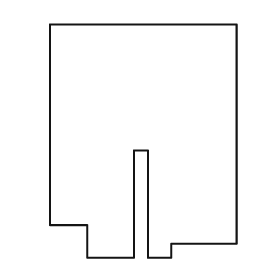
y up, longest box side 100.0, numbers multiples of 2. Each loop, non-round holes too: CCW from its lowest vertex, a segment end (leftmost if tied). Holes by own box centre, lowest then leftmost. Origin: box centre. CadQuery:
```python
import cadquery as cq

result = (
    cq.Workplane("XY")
    .moveTo(-24.0, -50.0)
    .lineTo(-4.0, -50.0)
    .lineTo(-4.0, -4.0)
    .lineTo(2.0, -4.0)
    .lineTo(2.0, -50.0)
    .lineTo(12.0, -50.0)
    .lineTo(12.0, -44.0)
    .lineTo(40.0, -44.0)
    .lineTo(40.0, 50.0)
    .lineTo(-40.0, 50.0)
    .lineTo(-40.0, -36.0)
    .lineTo(-24.0, -36.0)
    .close()
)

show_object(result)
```